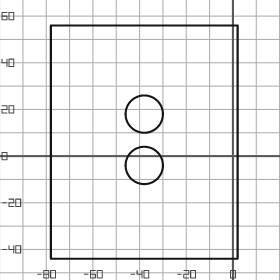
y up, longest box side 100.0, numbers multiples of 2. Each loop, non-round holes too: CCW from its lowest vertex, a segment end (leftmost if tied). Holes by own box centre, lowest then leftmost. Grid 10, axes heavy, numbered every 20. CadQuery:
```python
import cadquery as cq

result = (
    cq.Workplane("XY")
    .moveTo(-78.0, -44.0)
    .lineTo(2.0, -44.0)
    .lineTo(2.0, 56.0)
    .lineTo(-78.0, 56.0)
    .close()
    .moveTo(-38.0, -4.0)
    .circle(8.0)
    .moveTo(-38.0, 18.0)
    .circle(8.0)
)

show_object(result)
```